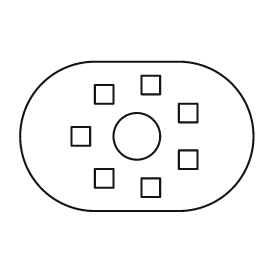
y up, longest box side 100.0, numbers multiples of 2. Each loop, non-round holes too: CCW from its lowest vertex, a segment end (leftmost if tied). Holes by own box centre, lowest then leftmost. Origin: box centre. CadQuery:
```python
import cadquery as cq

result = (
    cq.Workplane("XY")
    .moveTo(-18.0, -32.0)
    .lineTo(18.0, -32.0)
    .threePointArc((50.0, 0.0), (18.0, 32.0))
    .lineTo(-18.0, 32.0)
    .threePointArc((-50.0, 0.0), (-18.0, -32.0))
    .close()
    .moveTo(2.0, -26.0)
    .lineTo(10.0, -26.0)
    .lineTo(10.0, -18.0)
    .lineTo(2.0, -18.0)
    .close()
    .moveTo(-18.0, -22.0)
    .lineTo(-10.0, -22.0)
    .lineTo(-10.0, -14.0)
    .lineTo(-18.0, -14.0)
    .close()
    .moveTo(18.0, -14.0)
    .lineTo(26.0, -14.0)
    .lineTo(26.0, -6.0)
    .lineTo(18.0, -6.0)
    .close()
    .moveTo(-28.0, -4.0)
    .lineTo(-20.0, -4.0)
    .lineTo(-20.0, 4.0)
    .lineTo(-28.0, 4.0)
    .close()
    .moveTo(0.0, 0.0)
    .circle(10.0)
    .moveTo(18.0, 6.0)
    .lineTo(26.0, 6.0)
    .lineTo(26.0, 14.0)
    .lineTo(18.0, 14.0)
    .close()
    .moveTo(-18.0, 14.0)
    .lineTo(-10.0, 14.0)
    .lineTo(-10.0, 22.0)
    .lineTo(-18.0, 22.0)
    .close()
    .moveTo(2.0, 18.0)
    .lineTo(10.0, 18.0)
    .lineTo(10.0, 26.0)
    .lineTo(2.0, 26.0)
    .close()
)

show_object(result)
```